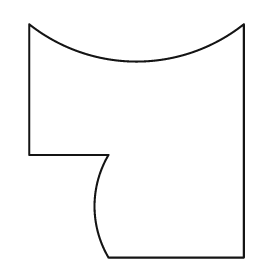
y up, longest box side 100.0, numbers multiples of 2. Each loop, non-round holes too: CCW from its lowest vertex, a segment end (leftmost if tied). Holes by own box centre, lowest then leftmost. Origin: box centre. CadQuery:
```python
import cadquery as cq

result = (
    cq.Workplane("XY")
    .moveTo(-12.0, -50.0)
    .lineTo(46.0, -50.0)
    .lineTo(46.0, 50.0)
    .threePointArc((0.0, 34.0), (-46.0, 50.0))
    .lineTo(-46.0, -6.0)
    .lineTo(-12.0, -6.0)
    .threePointArc((-18.0, -28.0), (-12.0, -50.0))
    .close()
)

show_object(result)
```